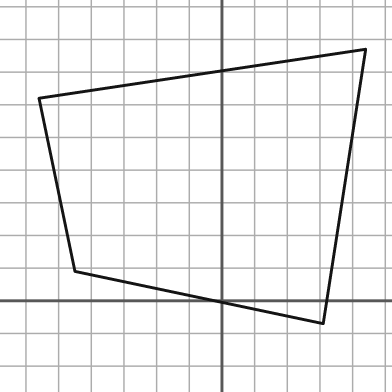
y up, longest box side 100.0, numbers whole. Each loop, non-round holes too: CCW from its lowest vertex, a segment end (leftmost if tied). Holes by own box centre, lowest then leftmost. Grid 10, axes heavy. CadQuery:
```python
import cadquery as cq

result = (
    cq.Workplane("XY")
    .moveTo(31.0, -7.0)
    .lineTo(44.0, 77.0)
    .lineTo(-56.0, 62.0)
    .lineTo(-45.0, 9.0)
    .close()
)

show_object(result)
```